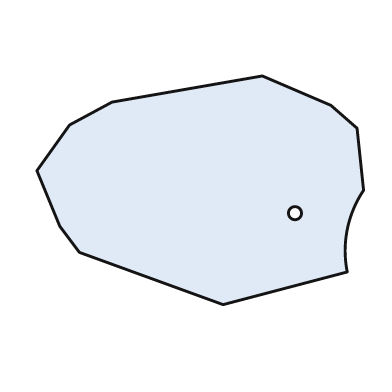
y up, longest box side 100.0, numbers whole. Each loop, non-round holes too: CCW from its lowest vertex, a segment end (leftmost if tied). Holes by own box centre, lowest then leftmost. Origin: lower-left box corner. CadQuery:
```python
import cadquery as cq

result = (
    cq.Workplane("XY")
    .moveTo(57.0, 0.0)
    .lineTo(95.0, 10.0)
    .threePointArc((95.0, 23.0), (100.0, 35.0))
    .lineTo(98.0, 54.0)
    .lineTo(90.0, 61.0)
    .lineTo(69.0, 70.0)
    .lineTo(23.0, 62.0)
    .lineTo(10.0, 55.0)
    .lineTo(0.0, 41.0)
    .lineTo(7.0, 24.0)
    .lineTo(13.0, 16.0)
    .close()
    .moveTo(79.0, 28.0)
    .circle(2.0)
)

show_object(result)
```